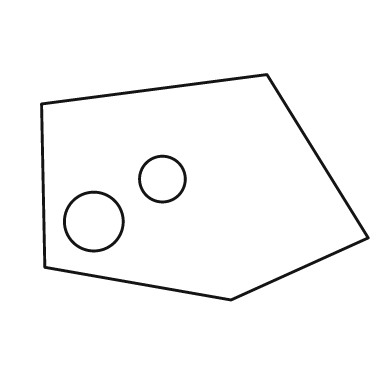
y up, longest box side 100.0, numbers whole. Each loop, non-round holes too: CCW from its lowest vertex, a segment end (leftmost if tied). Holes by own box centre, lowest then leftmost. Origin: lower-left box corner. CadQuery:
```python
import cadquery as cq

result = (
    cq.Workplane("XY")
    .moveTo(58.0, 0.0)
    .lineTo(100.0, 19.0)
    .lineTo(69.0, 69.0)
    .lineTo(0.0, 60.0)
    .lineTo(1.0, 10.0)
    .close()
    .moveTo(16.0, 24.0)
    .circle(9.0)
    .moveTo(37.0, 37.0)
    .circle(7.0)
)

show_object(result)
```